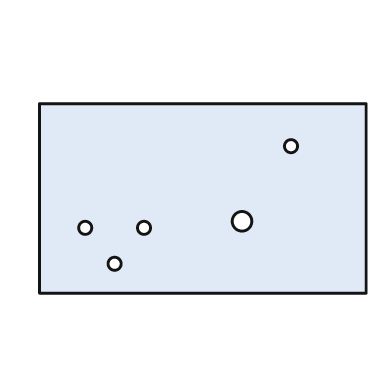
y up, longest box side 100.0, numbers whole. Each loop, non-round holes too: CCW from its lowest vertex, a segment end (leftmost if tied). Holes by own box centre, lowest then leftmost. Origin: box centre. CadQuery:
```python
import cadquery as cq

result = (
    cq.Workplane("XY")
    .moveTo(-50.0, -29.0)
    .lineTo(50.0, -29.0)
    .lineTo(50.0, 29.0)
    .lineTo(-50.0, 29.0)
    .close()
    .moveTo(-27.0, -20.0)
    .circle(2.0)
    .moveTo(-36.0, -9.0)
    .circle(2.0)
    .moveTo(-18.0, -9.0)
    .circle(2.0)
    .moveTo(12.0, -7.0)
    .circle(3.0)
    .moveTo(27.0, 16.0)
    .circle(2.0)
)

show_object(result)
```